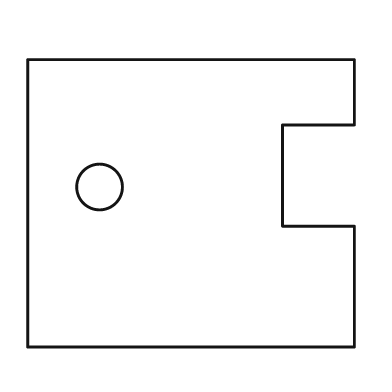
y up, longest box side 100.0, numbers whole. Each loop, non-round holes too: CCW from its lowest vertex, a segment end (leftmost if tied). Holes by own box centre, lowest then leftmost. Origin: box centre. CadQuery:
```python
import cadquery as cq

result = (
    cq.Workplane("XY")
    .moveTo(-50.0, -44.0)
    .lineTo(50.0, -44.0)
    .lineTo(50.0, -7.0)
    .lineTo(28.0, -7.0)
    .lineTo(28.0, 24.0)
    .lineTo(50.0, 24.0)
    .lineTo(50.0, 44.0)
    .lineTo(-50.0, 44.0)
    .close()
    .moveTo(-28.0, 5.0)
    .circle(7.0)
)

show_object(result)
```